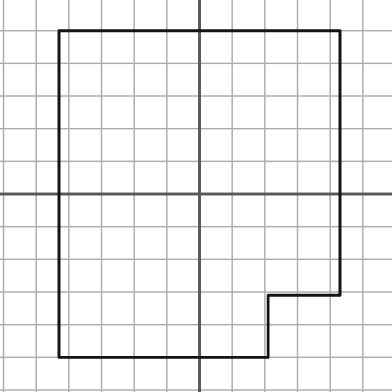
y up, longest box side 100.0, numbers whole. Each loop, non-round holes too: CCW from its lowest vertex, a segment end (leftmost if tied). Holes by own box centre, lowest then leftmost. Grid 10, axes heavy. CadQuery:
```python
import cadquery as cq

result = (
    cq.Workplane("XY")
    .moveTo(-43.0, -50.0)
    .lineTo(21.0, -50.0)
    .lineTo(21.0, -31.0)
    .lineTo(43.0, -31.0)
    .lineTo(43.0, 50.0)
    .lineTo(-43.0, 50.0)
    .close()
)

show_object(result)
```